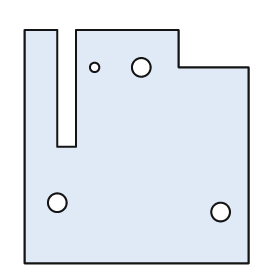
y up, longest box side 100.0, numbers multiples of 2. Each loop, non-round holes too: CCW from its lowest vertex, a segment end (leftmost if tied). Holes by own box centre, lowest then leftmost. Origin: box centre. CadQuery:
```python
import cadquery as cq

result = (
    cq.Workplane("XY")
    .moveTo(-48.0, -50.0)
    .lineTo(48.0, -50.0)
    .lineTo(48.0, 34.0)
    .lineTo(18.0, 34.0)
    .lineTo(18.0, 50.0)
    .lineTo(-26.0, 50.0)
    .lineTo(-26.0, 0.0)
    .lineTo(-34.0, 0.0)
    .lineTo(-34.0, 50.0)
    .lineTo(-48.0, 50.0)
    .close()
    .moveTo(36.0, -28.0)
    .circle(4.0)
    .moveTo(-34.0, -24.0)
    .circle(4.0)
    .moveTo(-18.0, 34.0)
    .circle(2.0)
    .moveTo(2.0, 34.0)
    .circle(4.0)
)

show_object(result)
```